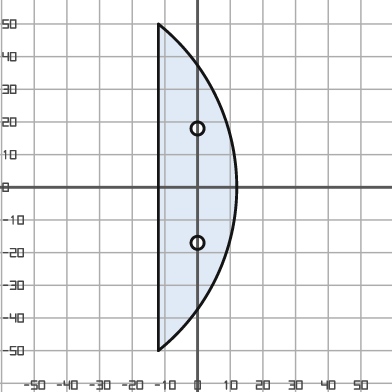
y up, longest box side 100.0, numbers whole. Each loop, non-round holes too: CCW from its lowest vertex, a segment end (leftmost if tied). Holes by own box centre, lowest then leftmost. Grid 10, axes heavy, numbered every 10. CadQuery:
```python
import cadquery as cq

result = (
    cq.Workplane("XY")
    .moveTo(-12.0, -50.0)
    .threePointArc((12.0, 0.0), (-12.0, 50.0))
    .close()
    .moveTo(0.0, -17.0)
    .circle(2.0)
    .moveTo(0.0, 18.0)
    .circle(2.0)
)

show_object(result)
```